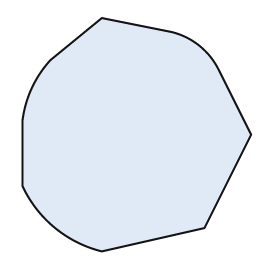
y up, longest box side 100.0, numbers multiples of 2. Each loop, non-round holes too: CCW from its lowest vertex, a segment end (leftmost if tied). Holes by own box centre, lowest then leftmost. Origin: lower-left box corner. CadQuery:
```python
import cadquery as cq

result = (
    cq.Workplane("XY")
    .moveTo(34.0, 0.0)
    .lineTo(78.0, 10.0)
    .lineTo(98.0, 50.0)
    .lineTo(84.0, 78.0)
    .threePointArc((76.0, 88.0), (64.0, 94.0))
    .lineTo(34.0, 100.0)
    .lineTo(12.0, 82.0)
    .threePointArc((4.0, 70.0), (0.0, 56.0))
    .lineTo(0.0, 28.0)
    .threePointArc((14.0, 10.0), (34.0, 0.0))
    .close()
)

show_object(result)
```